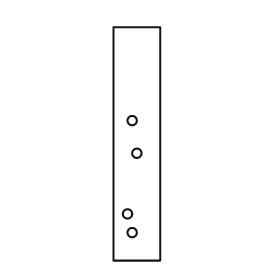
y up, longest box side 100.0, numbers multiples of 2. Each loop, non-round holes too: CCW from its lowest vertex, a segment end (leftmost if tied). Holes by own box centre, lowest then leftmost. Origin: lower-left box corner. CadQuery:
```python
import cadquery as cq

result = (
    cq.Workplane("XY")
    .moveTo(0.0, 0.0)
    .lineTo(20.0, 0.0)
    .lineTo(20.0, 100.0)
    .lineTo(0.0, 100.0)
    .close()
    .moveTo(8.0, 12.0)
    .circle(2.0)
    .moveTo(6.0, 20.0)
    .circle(2.0)
    .moveTo(10.0, 46.0)
    .circle(2.0)
    .moveTo(8.0, 60.0)
    .circle(2.0)
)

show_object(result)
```